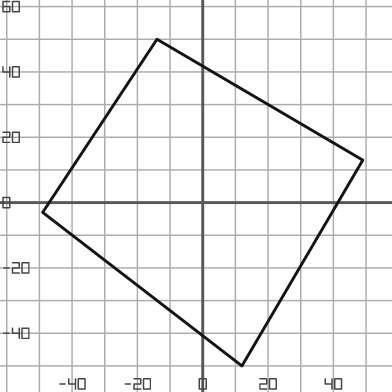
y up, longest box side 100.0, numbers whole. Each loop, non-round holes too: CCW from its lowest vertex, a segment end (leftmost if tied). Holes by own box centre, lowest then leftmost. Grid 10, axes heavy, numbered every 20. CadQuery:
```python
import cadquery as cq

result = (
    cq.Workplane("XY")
    .moveTo(12.0, -50.0)
    .lineTo(49.0, 13.0)
    .lineTo(-14.0, 50.0)
    .lineTo(-49.0, -3.0)
    .close()
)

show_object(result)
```